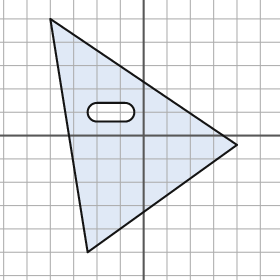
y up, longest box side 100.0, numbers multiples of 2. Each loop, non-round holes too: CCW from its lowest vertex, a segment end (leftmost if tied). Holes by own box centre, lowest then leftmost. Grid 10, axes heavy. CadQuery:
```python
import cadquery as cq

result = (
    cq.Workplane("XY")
    .moveTo(-24.0, -50.0)
    .lineTo(40.0, -4.0)
    .lineTo(-40.0, 50.0)
    .close()
    .moveTo(-20.0, 6.0)
    .lineTo(-8.0, 6.0)
    .threePointArc((-4.0, 10.0), (-8.0, 14.0))
    .lineTo(-20.0, 14.0)
    .threePointArc((-24.0, 10.0), (-20.0, 6.0))
    .close()
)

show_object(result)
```